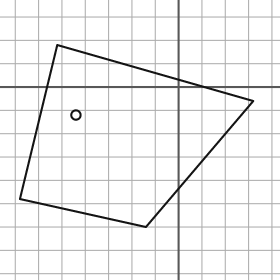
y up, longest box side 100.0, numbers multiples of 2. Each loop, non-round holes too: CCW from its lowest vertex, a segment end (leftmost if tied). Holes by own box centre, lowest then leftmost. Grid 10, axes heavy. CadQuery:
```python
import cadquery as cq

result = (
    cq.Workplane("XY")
    .moveTo(-14.0, -60.0)
    .lineTo(32.0, -6.0)
    .lineTo(-52.0, 18.0)
    .lineTo(-68.0, -48.0)
    .close()
    .moveTo(-44.0, -12.0)
    .circle(2.0)
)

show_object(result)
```